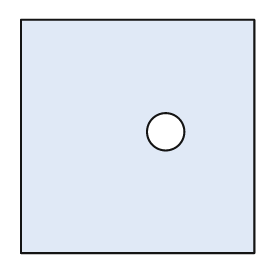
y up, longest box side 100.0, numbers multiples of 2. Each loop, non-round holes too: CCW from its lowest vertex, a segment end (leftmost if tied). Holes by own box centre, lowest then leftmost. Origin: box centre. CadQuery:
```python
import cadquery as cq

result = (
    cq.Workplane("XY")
    .moveTo(-50.0, -50.0)
    .lineTo(50.0, -50.0)
    .lineTo(50.0, 50.0)
    .lineTo(-50.0, 50.0)
    .close()
    .moveTo(12.0, 2.0)
    .circle(8.0)
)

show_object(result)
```